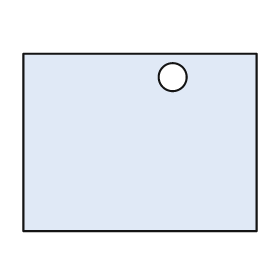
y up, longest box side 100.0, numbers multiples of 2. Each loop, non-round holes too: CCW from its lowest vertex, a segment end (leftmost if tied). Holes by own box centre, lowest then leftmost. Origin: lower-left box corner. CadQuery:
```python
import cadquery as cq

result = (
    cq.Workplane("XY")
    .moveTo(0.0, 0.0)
    .lineTo(100.0, 0.0)
    .lineTo(100.0, 76.0)
    .lineTo(0.0, 76.0)
    .close()
    .moveTo(64.0, 66.0)
    .circle(6.0)
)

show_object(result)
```